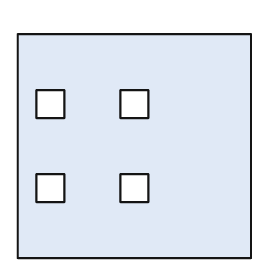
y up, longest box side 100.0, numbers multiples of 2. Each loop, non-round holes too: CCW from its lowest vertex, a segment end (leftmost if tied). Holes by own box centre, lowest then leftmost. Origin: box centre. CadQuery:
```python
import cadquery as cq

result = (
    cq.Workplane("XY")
    .moveTo(-50.0, -48.0)
    .lineTo(50.0, -48.0)
    .lineTo(50.0, 48.0)
    .lineTo(-50.0, 48.0)
    .close()
    .moveTo(-42.0, -24.0)
    .lineTo(-30.0, -24.0)
    .lineTo(-30.0, -12.0)
    .lineTo(-42.0, -12.0)
    .close()
    .moveTo(-6.0, -24.0)
    .lineTo(6.0, -24.0)
    .lineTo(6.0, -12.0)
    .lineTo(-6.0, -12.0)
    .close()
    .moveTo(-42.0, 12.0)
    .lineTo(-30.0, 12.0)
    .lineTo(-30.0, 24.0)
    .lineTo(-42.0, 24.0)
    .close()
    .moveTo(-6.0, 12.0)
    .lineTo(6.0, 12.0)
    .lineTo(6.0, 24.0)
    .lineTo(-6.0, 24.0)
    .close()
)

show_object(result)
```